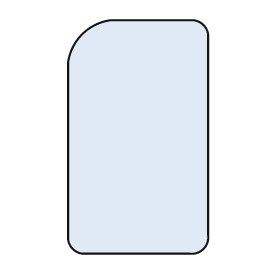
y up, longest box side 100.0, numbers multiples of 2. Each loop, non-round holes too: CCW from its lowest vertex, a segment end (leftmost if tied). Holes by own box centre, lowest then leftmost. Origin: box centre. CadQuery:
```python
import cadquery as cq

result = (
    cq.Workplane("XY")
    .moveTo(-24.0, -50.0)
    .lineTo(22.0, -50.0)
    .threePointArc((28.0, -48.0), (30.0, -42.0))
    .lineTo(30.0, 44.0)
    .threePointArc((28.0, 48.0), (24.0, 50.0))
    .lineTo(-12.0, 50.0)
    .threePointArc((-24.0, 44.0), (-30.0, 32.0))
    .lineTo(-30.0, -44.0)
    .threePointArc((-28.0, -48.0), (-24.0, -50.0))
    .close()
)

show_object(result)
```